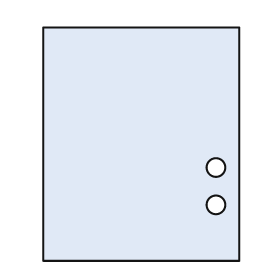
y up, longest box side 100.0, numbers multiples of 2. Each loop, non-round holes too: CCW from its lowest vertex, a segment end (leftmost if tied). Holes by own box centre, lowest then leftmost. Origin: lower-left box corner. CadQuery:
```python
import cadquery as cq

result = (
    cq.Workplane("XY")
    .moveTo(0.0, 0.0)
    .lineTo(84.0, 0.0)
    .lineTo(84.0, 100.0)
    .lineTo(0.0, 100.0)
    .close()
    .moveTo(74.0, 24.0)
    .circle(4.0)
    .moveTo(74.0, 40.0)
    .circle(4.0)
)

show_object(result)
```